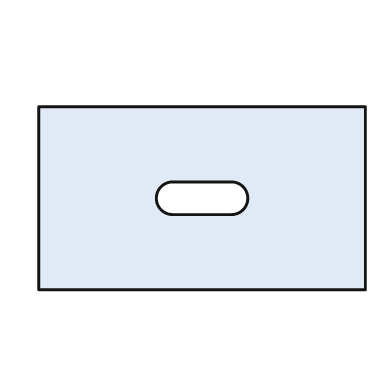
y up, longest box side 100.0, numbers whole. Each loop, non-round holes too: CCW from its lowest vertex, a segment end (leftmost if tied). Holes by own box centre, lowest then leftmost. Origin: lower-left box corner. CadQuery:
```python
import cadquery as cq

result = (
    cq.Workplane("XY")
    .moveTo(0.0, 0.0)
    .lineTo(100.0, 0.0)
    .lineTo(100.0, 56.0)
    .lineTo(0.0, 56.0)
    .close()
    .moveTo(41.0, 23.0)
    .lineTo(59.0, 23.0)
    .threePointArc((64.0, 28.0), (59.0, 33.0))
    .lineTo(41.0, 33.0)
    .threePointArc((36.0, 28.0), (41.0, 23.0))
    .close()
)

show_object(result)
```